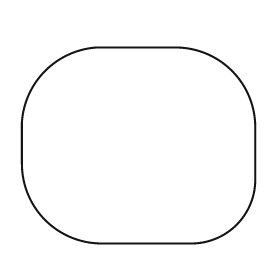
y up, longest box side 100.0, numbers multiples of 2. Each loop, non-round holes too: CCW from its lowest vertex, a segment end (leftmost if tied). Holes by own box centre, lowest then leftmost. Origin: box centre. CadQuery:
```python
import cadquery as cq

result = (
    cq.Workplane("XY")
    .moveTo(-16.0, -42.0)
    .lineTo(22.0, -42.0)
    .threePointArc((42.0, -34.0), (50.0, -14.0))
    .lineTo(50.0, 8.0)
    .threePointArc((40.0, 32.0), (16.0, 42.0))
    .lineTo(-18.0, 42.0)
    .threePointArc((-40.0, 32.0), (-50.0, 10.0))
    .lineTo(-50.0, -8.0)
    .threePointArc((-40.0, -32.0), (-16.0, -42.0))
    .close()
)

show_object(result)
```